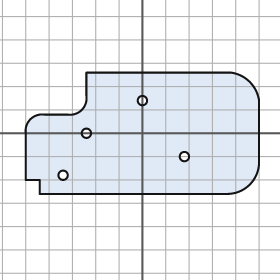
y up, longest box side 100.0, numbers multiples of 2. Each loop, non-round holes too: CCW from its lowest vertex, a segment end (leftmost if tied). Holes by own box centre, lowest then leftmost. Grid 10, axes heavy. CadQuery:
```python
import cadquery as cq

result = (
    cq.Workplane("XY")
    .moveTo(-44.0, -26.0)
    .lineTo(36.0, -26.0)
    .threePointArc((46.0, -22.0), (50.0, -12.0))
    .lineTo(50.0, 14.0)
    .threePointArc((46.0, 22.0), (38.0, 26.0))
    .lineTo(-24.0, 26.0)
    .lineTo(-24.0, 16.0)
    .threePointArc((-26.0, 10.0), (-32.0, 8.0))
    .lineTo(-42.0, 8.0)
    .threePointArc((-48.0, 6.0), (-50.0, 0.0))
    .lineTo(-50.0, -20.0)
    .lineTo(-44.0, -20.0)
    .close()
    .moveTo(-34.0, -18.0)
    .circle(2.0)
    .moveTo(18.0, -10.0)
    .circle(2.0)
    .moveTo(-24.0, 0.0)
    .circle(2.0)
    .moveTo(0.0, 14.0)
    .circle(2.0)
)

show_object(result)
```